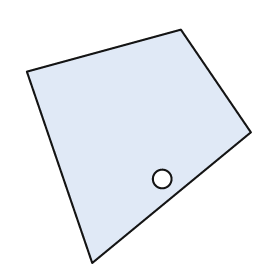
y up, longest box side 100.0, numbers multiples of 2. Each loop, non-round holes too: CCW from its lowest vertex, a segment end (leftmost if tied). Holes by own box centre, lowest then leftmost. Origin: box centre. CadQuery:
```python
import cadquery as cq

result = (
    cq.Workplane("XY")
    .moveTo(-20.0, -50.0)
    .lineTo(48.0, 6.0)
    .lineTo(18.0, 50.0)
    .lineTo(-48.0, 32.0)
    .close()
    .moveTo(10.0, -14.0)
    .circle(4.0)
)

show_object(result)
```